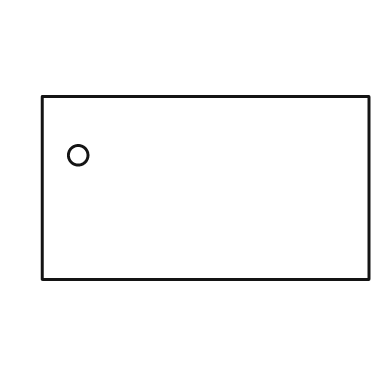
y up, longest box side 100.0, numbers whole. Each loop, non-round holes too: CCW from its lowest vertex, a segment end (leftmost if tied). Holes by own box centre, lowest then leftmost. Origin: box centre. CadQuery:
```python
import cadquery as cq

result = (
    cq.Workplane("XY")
    .moveTo(-50.0, -28.0)
    .lineTo(50.0, -28.0)
    .lineTo(50.0, 28.0)
    .lineTo(-50.0, 28.0)
    .close()
    .moveTo(-39.0, 10.0)
    .circle(3.0)
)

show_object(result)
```